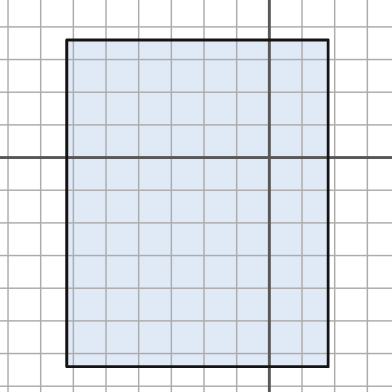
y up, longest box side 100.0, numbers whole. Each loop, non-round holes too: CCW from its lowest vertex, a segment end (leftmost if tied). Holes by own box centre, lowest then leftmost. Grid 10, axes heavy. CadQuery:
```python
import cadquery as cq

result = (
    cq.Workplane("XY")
    .moveTo(-62.0, -64.0)
    .lineTo(18.0, -64.0)
    .lineTo(18.0, 36.0)
    .lineTo(-62.0, 36.0)
    .close()
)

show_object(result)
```